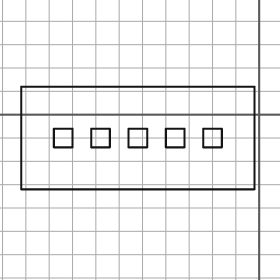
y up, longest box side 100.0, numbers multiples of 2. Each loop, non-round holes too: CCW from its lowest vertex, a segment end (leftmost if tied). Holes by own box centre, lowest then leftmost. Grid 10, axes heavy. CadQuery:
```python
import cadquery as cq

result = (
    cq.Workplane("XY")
    .moveTo(-102.0, -32.0)
    .lineTo(-2.0, -32.0)
    .lineTo(-2.0, 12.0)
    .lineTo(-102.0, 12.0)
    .close()
    .moveTo(-88.0, -14.0)
    .lineTo(-80.0, -14.0)
    .lineTo(-80.0, -6.0)
    .lineTo(-88.0, -6.0)
    .close()
    .moveTo(-72.0, -14.0)
    .lineTo(-64.0, -14.0)
    .lineTo(-64.0, -6.0)
    .lineTo(-72.0, -6.0)
    .close()
    .moveTo(-56.0, -14.0)
    .lineTo(-48.0, -14.0)
    .lineTo(-48.0, -6.0)
    .lineTo(-56.0, -6.0)
    .close()
    .moveTo(-40.0, -14.0)
    .lineTo(-32.0, -14.0)
    .lineTo(-32.0, -6.0)
    .lineTo(-40.0, -6.0)
    .close()
    .moveTo(-24.0, -14.0)
    .lineTo(-16.0, -14.0)
    .lineTo(-16.0, -6.0)
    .lineTo(-24.0, -6.0)
    .close()
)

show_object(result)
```